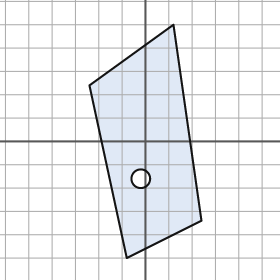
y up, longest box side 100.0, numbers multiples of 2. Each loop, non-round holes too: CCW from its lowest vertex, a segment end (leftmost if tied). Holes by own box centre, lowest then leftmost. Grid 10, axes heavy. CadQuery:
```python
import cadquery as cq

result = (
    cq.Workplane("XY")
    .moveTo(-8.0, -50.0)
    .lineTo(24.0, -34.0)
    .lineTo(12.0, 50.0)
    .lineTo(-24.0, 24.0)
    .close()
    .moveTo(-2.0, -16.0)
    .circle(4.0)
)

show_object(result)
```